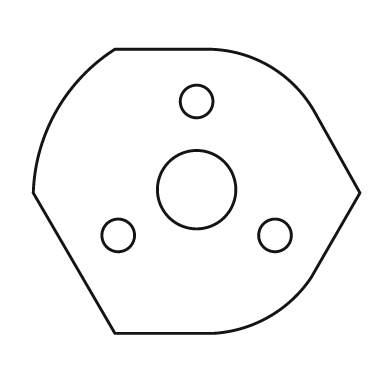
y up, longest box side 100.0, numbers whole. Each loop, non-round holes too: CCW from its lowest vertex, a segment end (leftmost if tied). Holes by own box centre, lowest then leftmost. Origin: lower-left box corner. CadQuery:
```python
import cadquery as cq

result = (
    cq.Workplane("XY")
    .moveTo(25.0, 0.0)
    .lineTo(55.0, 0.0)
    .threePointArc((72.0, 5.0), (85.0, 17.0))
    .lineTo(100.0, 43.0)
    .lineTo(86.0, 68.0)
    .threePointArc((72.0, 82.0), (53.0, 87.0))
    .lineTo(25.0, 87.0)
    .threePointArc((7.0, 68.0), (0.0, 43.0))
    .close()
    .moveTo(26.0, 30.0)
    .circle(5.0)
    .moveTo(74.0, 30.0)
    .circle(5.0)
    .moveTo(50.0, 44.0)
    .circle(12.0)
    .moveTo(50.0, 71.0)
    .circle(5.0)
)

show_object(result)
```